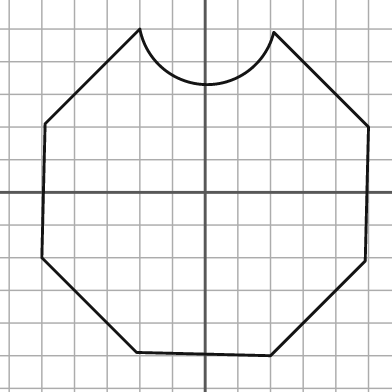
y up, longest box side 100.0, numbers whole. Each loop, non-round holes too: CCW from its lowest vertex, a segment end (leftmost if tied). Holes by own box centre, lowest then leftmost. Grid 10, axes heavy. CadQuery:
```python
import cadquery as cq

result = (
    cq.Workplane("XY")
    .moveTo(20.0, -50.0)
    .lineTo(49.0, -21.0)
    .lineTo(50.0, 20.0)
    .lineTo(21.0, 49.0)
    .threePointArc((0.0, 33.0), (-20.0, 50.0))
    .lineTo(-49.0, 21.0)
    .lineTo(-50.0, -20.0)
    .lineTo(-21.0, -49.0)
    .close()
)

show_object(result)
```